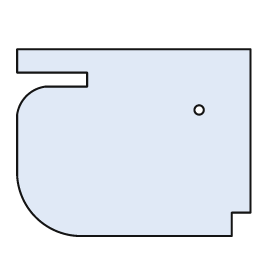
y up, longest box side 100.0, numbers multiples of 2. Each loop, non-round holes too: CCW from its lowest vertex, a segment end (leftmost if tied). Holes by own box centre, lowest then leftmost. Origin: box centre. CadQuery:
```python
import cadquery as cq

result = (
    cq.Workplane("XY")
    .moveTo(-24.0, -40.0)
    .lineTo(42.0, -40.0)
    .lineTo(42.0, -30.0)
    .lineTo(50.0, -30.0)
    .lineTo(50.0, 40.0)
    .lineTo(-50.0, 40.0)
    .lineTo(-50.0, 30.0)
    .lineTo(-20.0, 30.0)
    .lineTo(-20.0, 24.0)
    .lineTo(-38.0, 24.0)
    .threePointArc((-46.0, 20.0), (-50.0, 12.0))
    .lineTo(-50.0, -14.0)
    .threePointArc((-42.0, -32.0), (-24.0, -40.0))
    .close()
    .moveTo(28.0, 14.0)
    .circle(2.0)
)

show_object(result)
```